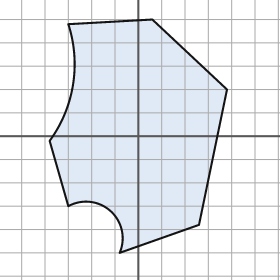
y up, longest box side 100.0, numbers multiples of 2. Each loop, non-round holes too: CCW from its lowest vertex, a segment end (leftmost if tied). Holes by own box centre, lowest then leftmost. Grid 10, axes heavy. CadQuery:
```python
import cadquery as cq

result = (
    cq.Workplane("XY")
    .moveTo(-8.0, -50.0)
    .lineTo(26.0, -38.0)
    .lineTo(38.0, 20.0)
    .lineTo(6.0, 50.0)
    .lineTo(-30.0, 48.0)
    .threePointArc((-28.0, 22.0), (-38.0, -2.0))
    .lineTo(-30.0, -30.0)
    .threePointArc((-12.0, -32.0), (-8.0, -50.0))
    .close()
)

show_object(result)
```